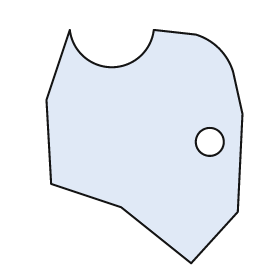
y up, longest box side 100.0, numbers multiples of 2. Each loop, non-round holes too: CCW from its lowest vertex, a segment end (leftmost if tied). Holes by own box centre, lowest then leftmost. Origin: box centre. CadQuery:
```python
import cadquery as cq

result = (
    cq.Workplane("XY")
    .moveTo(20.0, -50.0)
    .lineTo(40.0, -28.0)
    .lineTo(42.0, 14.0)
    .lineTo(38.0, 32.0)
    .threePointArc((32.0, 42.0), (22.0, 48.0))
    .lineTo(4.0, 50.0)
    .threePointArc((-14.0, 34.0), (-32.0, 50.0))
    .lineTo(-42.0, 20.0)
    .lineTo(-40.0, -16.0)
    .lineTo(-10.0, -26.0)
    .close()
    .moveTo(28.0, 2.0)
    .circle(6.0)
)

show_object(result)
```